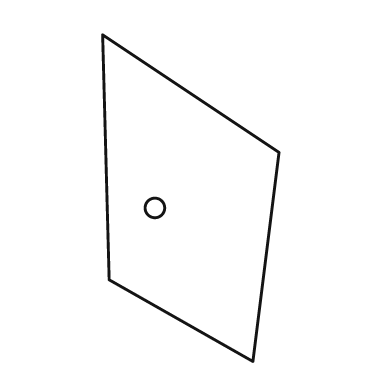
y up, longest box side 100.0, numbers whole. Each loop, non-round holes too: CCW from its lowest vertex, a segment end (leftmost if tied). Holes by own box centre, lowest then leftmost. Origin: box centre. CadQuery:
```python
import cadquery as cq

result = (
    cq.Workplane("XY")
    .moveTo(19.0, -50.0)
    .lineTo(27.0, 14.0)
    .lineTo(-27.0, 50.0)
    .lineTo(-25.0, -25.0)
    .close()
    .moveTo(-11.0, -3.0)
    .circle(3.0)
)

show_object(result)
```